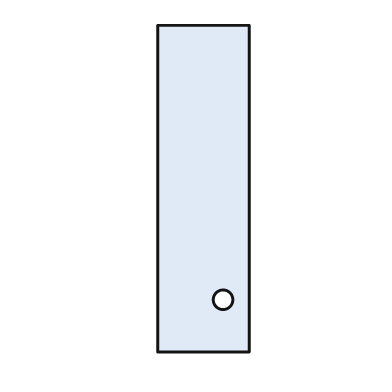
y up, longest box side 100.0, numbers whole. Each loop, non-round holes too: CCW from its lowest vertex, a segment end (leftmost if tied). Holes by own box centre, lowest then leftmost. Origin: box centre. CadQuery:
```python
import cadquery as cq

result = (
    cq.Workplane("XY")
    .moveTo(-14.0, -50.0)
    .lineTo(14.0, -50.0)
    .lineTo(14.0, 50.0)
    .lineTo(-14.0, 50.0)
    .close()
    .moveTo(6.0, -34.0)
    .circle(3.0)
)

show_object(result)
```